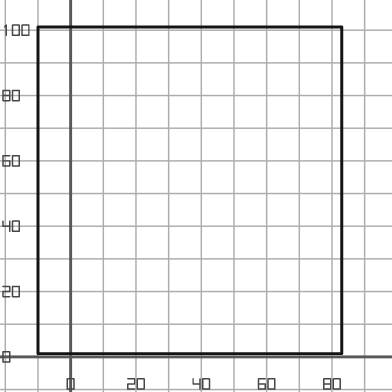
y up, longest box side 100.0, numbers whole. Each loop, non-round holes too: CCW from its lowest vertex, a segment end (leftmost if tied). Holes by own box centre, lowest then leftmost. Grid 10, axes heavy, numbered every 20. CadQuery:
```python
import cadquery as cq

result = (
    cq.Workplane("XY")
    .moveTo(-10.0, 1.0)
    .lineTo(83.0, 1.0)
    .lineTo(83.0, 101.0)
    .lineTo(-10.0, 101.0)
    .close()
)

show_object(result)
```